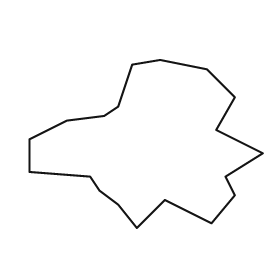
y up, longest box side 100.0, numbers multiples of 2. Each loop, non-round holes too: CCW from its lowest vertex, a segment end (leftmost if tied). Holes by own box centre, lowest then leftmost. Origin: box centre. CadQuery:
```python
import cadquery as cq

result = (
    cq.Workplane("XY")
    .moveTo(-4.0, -36.0)
    .lineTo(8.0, -24.0)
    .lineTo(28.0, -34.0)
    .lineTo(38.0, -22.0)
    .lineTo(34.0, -14.0)
    .lineTo(50.0, -4.0)
    .lineTo(30.0, 6.0)
    .lineTo(38.0, 20.0)
    .lineTo(26.0, 32.0)
    .lineTo(6.0, 36.0)
    .lineTo(-6.0, 34.0)
    .lineTo(-12.0, 16.0)
    .lineTo(-18.0, 12.0)
    .lineTo(-34.0, 10.0)
    .lineTo(-50.0, 2.0)
    .lineTo(-50.0, -12.0)
    .lineTo(-24.0, -14.0)
    .lineTo(-20.0, -20.0)
    .lineTo(-12.0, -26.0)
    .close()
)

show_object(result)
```